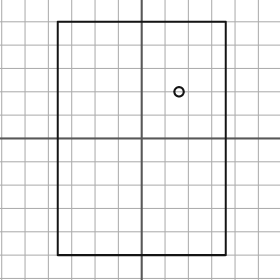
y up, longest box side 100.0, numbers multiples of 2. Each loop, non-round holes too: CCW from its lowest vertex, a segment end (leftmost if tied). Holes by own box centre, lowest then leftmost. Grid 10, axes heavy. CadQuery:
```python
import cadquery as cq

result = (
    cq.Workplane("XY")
    .moveTo(-36.0, -50.0)
    .lineTo(36.0, -50.0)
    .lineTo(36.0, 50.0)
    .lineTo(-36.0, 50.0)
    .close()
    .moveTo(16.0, 20.0)
    .circle(2.0)
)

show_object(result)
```